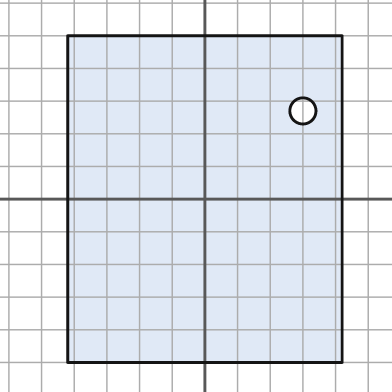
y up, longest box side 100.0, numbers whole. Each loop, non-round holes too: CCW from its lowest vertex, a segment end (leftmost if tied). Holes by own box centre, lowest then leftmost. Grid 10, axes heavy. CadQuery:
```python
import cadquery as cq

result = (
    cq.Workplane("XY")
    .moveTo(-42.0, -50.0)
    .lineTo(42.0, -50.0)
    .lineTo(42.0, 50.0)
    .lineTo(-42.0, 50.0)
    .close()
    .moveTo(30.0, 27.0)
    .circle(4.0)
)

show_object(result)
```